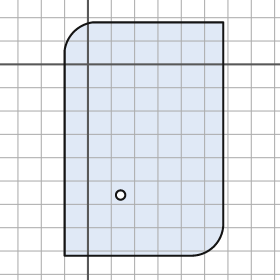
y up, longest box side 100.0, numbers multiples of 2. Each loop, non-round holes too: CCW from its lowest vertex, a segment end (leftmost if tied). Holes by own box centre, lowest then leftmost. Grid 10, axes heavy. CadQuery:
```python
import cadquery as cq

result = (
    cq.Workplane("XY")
    .moveTo(-10.0, -82.0)
    .lineTo(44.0, -82.0)
    .threePointArc((54.0, -78.0), (58.0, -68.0))
    .lineTo(58.0, 18.0)
    .lineTo(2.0, 18.0)
    .threePointArc((-6.0, 14.0), (-10.0, 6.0))
    .close()
    .moveTo(14.0, -56.0)
    .circle(2.0)
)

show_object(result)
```